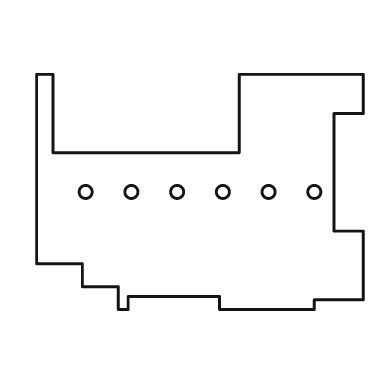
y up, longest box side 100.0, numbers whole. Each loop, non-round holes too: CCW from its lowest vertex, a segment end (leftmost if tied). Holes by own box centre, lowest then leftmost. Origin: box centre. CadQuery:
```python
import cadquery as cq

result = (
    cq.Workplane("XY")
    .moveTo(-25.0, -36.0)
    .lineTo(-22.0, -36.0)
    .lineTo(-22.0, -32.0)
    .lineTo(6.0, -32.0)
    .lineTo(6.0, -36.0)
    .lineTo(35.0, -36.0)
    .lineTo(35.0, -33.0)
    .lineTo(50.0, -33.0)
    .lineTo(50.0, -12.0)
    .lineTo(41.0, -12.0)
    .lineTo(41.0, 24.0)
    .lineTo(50.0, 24.0)
    .lineTo(50.0, 36.0)
    .lineTo(12.0, 36.0)
    .lineTo(12.0, 12.0)
    .lineTo(-45.0, 12.0)
    .lineTo(-45.0, 36.0)
    .lineTo(-50.0, 36.0)
    .lineTo(-50.0, -22.0)
    .lineTo(-36.0, -22.0)
    .lineTo(-36.0, -29.0)
    .lineTo(-25.0, -29.0)
    .close()
    .moveTo(-35.0, 0.0)
    .circle(2.0)
    .moveTo(-21.0, 0.0)
    .circle(2.0)
    .moveTo(-7.0, 0.0)
    .circle(2.0)
    .moveTo(7.0, 0.0)
    .circle(2.0)
    .moveTo(21.0, 0.0)
    .circle(2.0)
    .moveTo(35.0, 0.0)
    .circle(2.0)
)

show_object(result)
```